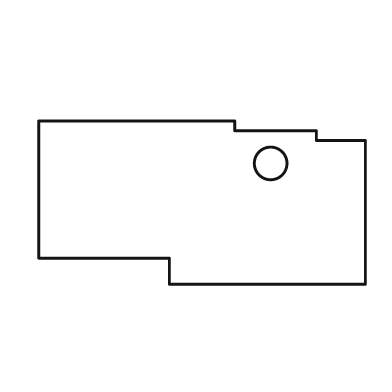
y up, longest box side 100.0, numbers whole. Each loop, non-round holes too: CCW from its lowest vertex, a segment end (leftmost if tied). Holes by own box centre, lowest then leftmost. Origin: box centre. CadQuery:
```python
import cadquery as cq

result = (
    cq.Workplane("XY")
    .moveTo(-10.0, -25.0)
    .lineTo(50.0, -25.0)
    .lineTo(50.0, 19.0)
    .lineTo(35.0, 19.0)
    .lineTo(35.0, 22.0)
    .lineTo(10.0, 22.0)
    .lineTo(10.0, 25.0)
    .lineTo(-50.0, 25.0)
    .lineTo(-50.0, -17.0)
    .lineTo(-10.0, -17.0)
    .close()
    .moveTo(21.0, 12.0)
    .circle(5.0)
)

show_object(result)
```